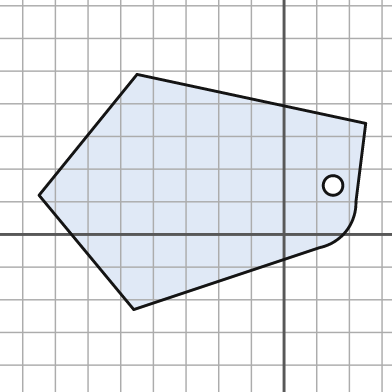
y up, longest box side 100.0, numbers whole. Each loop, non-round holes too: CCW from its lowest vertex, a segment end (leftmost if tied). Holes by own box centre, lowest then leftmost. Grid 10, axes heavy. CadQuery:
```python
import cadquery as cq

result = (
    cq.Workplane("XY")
    .moveTo(-46.0, -23.0)
    .lineTo(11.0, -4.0)
    .threePointArc((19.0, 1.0), (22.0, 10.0))
    .lineTo(25.0, 34.0)
    .lineTo(-45.0, 49.0)
    .lineTo(-75.0, 12.0)
    .close()
    .moveTo(15.0, 15.0)
    .circle(3.0)
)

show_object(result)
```